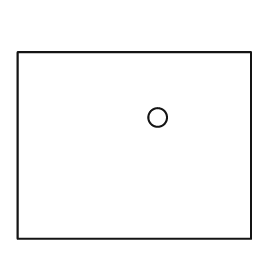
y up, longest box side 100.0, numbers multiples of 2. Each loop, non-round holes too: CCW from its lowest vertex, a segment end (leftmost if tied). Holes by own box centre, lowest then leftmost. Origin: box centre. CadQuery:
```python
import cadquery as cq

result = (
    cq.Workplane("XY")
    .moveTo(-50.0, -40.0)
    .lineTo(50.0, -40.0)
    .lineTo(50.0, 40.0)
    .lineTo(-50.0, 40.0)
    .close()
    .moveTo(10.0, 12.0)
    .circle(4.0)
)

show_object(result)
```